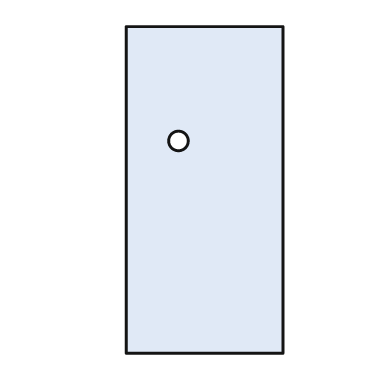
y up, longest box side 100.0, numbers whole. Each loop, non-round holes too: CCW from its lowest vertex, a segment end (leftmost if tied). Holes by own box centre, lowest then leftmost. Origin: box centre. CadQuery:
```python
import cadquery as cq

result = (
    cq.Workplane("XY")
    .moveTo(-24.0, -50.0)
    .lineTo(24.0, -50.0)
    .lineTo(24.0, 50.0)
    .lineTo(-24.0, 50.0)
    .close()
    .moveTo(-8.0, 15.0)
    .circle(3.0)
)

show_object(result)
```